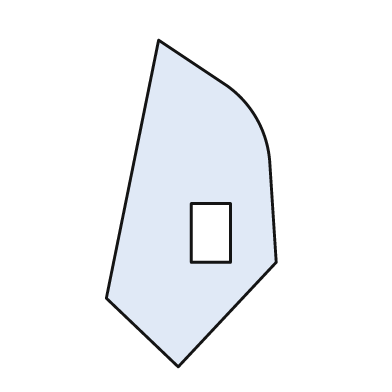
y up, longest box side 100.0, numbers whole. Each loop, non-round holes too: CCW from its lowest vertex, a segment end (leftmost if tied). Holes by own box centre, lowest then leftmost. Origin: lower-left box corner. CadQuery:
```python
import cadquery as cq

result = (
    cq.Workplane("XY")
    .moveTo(22.0, 0.0)
    .lineTo(52.0, 32.0)
    .lineTo(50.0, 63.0)
    .threePointArc((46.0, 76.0), (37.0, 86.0))
    .lineTo(16.0, 100.0)
    .lineTo(0.0, 21.0)
    .close()
    .moveTo(26.0, 32.0)
    .lineTo(38.0, 32.0)
    .lineTo(38.0, 50.0)
    .lineTo(26.0, 50.0)
    .close()
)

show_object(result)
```